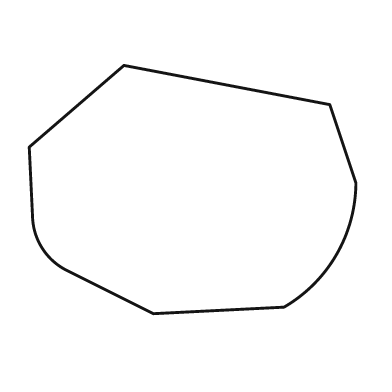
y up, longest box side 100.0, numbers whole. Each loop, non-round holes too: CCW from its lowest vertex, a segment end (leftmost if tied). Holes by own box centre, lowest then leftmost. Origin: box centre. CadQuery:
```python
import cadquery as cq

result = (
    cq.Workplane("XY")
    .moveTo(-12.0, -38.0)
    .lineTo(28.0, -36.0)
    .threePointArc((44.0, -20.0), (50.0, 2.0))
    .lineTo(42.0, 26.0)
    .lineTo(-21.0, 38.0)
    .lineTo(-50.0, 13.0)
    .lineTo(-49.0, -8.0)
    .threePointArc((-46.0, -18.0), (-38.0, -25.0))
    .close()
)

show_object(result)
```